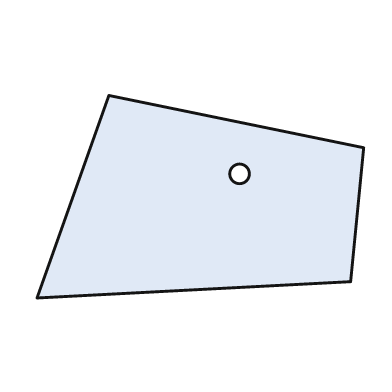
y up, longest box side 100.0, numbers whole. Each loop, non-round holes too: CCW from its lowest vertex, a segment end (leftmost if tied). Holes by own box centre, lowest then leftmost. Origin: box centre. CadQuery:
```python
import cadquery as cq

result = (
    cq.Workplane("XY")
    .moveTo(-50.0, -31.0)
    .lineTo(46.0, -26.0)
    .lineTo(50.0, 15.0)
    .lineTo(-28.0, 31.0)
    .close()
    .moveTo(12.0, 7.0)
    .circle(3.0)
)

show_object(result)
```